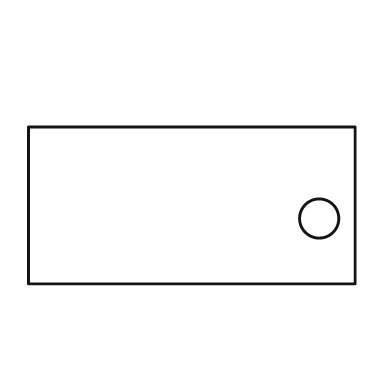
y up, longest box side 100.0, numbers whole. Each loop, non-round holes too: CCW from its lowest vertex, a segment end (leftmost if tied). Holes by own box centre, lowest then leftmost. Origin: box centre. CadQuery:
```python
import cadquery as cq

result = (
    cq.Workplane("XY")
    .moveTo(-50.0, -24.0)
    .lineTo(50.0, -24.0)
    .lineTo(50.0, 24.0)
    .lineTo(-50.0, 24.0)
    .close()
    .moveTo(39.0, -4.0)
    .circle(6.0)
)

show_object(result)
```